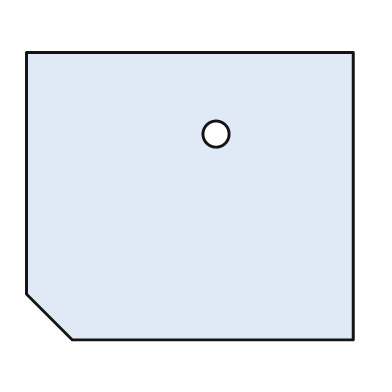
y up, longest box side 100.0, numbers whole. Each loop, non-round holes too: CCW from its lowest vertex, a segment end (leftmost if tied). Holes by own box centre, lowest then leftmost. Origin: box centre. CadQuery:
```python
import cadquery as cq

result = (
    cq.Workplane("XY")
    .moveTo(-36.0, -44.0)
    .lineTo(50.0, -44.0)
    .lineTo(50.0, 44.0)
    .lineTo(-50.0, 44.0)
    .lineTo(-50.0, -30.0)
    .close()
    .moveTo(8.0, 19.0)
    .circle(4.0)
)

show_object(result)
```